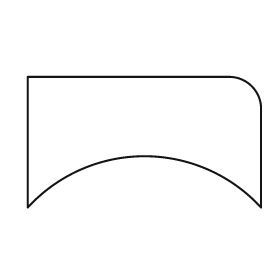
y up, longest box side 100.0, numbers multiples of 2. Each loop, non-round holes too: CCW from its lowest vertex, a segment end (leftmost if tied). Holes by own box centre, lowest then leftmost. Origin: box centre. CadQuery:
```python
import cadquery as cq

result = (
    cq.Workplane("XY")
    .moveTo(-50.0, -28.0)
    .threePointArc((0.0, -6.0), (50.0, -28.0))
    .lineTo(50.0, 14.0)
    .threePointArc((46.0, 24.0), (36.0, 28.0))
    .lineTo(-50.0, 28.0)
    .close()
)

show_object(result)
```